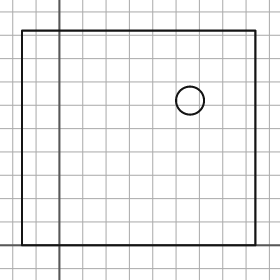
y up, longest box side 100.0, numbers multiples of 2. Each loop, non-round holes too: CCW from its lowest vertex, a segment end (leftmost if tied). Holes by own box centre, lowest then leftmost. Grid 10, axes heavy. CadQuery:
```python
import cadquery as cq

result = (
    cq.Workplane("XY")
    .moveTo(-16.0, 0.0)
    .lineTo(84.0, 0.0)
    .lineTo(84.0, 92.0)
    .lineTo(-16.0, 92.0)
    .close()
    .moveTo(56.0, 62.0)
    .circle(6.0)
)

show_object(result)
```